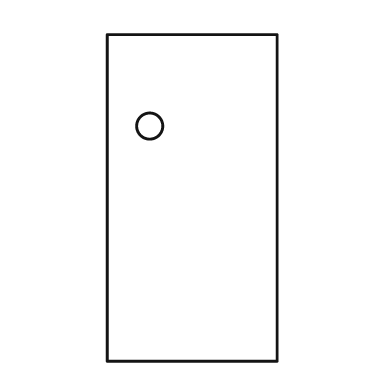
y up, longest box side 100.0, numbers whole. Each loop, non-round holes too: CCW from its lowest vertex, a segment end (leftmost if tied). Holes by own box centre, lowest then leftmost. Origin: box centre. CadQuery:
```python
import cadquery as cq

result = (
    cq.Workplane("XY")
    .moveTo(-26.0, -50.0)
    .lineTo(26.0, -50.0)
    .lineTo(26.0, 50.0)
    .lineTo(-26.0, 50.0)
    .close()
    .moveTo(-13.0, 22.0)
    .circle(4.0)
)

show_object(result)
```